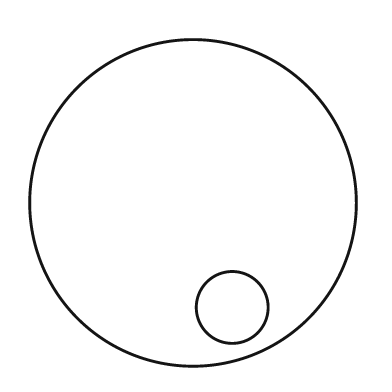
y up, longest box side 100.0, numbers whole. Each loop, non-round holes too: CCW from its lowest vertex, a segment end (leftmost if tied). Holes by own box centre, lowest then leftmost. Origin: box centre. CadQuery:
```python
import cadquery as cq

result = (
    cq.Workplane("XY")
    .moveTo(0.0, 0.0)
    .circle(50.0)
    .moveTo(12.0, -32.0)
    .circle(11.0)
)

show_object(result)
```